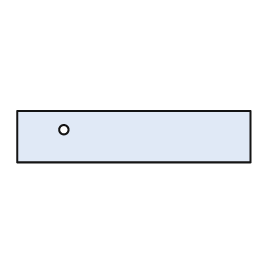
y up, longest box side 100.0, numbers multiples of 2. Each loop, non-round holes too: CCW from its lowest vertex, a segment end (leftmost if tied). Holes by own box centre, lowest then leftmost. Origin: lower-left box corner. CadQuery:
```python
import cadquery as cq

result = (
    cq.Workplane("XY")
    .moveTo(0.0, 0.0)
    .lineTo(100.0, 0.0)
    .lineTo(100.0, 22.0)
    .lineTo(0.0, 22.0)
    .close()
    .moveTo(20.0, 14.0)
    .circle(2.0)
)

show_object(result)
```